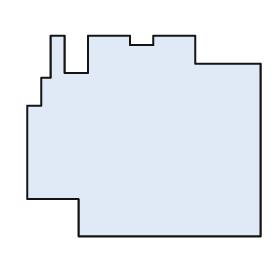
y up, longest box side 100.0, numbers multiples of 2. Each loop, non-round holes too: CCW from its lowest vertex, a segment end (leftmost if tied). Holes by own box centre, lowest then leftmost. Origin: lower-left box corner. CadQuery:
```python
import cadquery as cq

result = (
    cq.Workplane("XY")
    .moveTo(22.0, 0.0)
    .lineTo(100.0, 0.0)
    .lineTo(100.0, 74.0)
    .lineTo(72.0, 74.0)
    .lineTo(72.0, 86.0)
    .lineTo(54.0, 86.0)
    .lineTo(54.0, 82.0)
    .lineTo(44.0, 82.0)
    .lineTo(44.0, 86.0)
    .lineTo(26.0, 86.0)
    .lineTo(26.0, 70.0)
    .lineTo(16.0, 70.0)
    .lineTo(16.0, 86.0)
    .lineTo(10.0, 86.0)
    .lineTo(10.0, 68.0)
    .lineTo(6.0, 68.0)
    .lineTo(6.0, 56.0)
    .lineTo(0.0, 56.0)
    .lineTo(0.0, 16.0)
    .lineTo(22.0, 16.0)
    .close()
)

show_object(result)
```